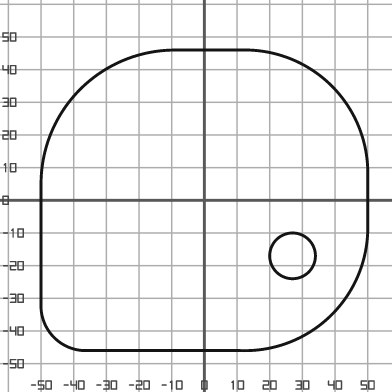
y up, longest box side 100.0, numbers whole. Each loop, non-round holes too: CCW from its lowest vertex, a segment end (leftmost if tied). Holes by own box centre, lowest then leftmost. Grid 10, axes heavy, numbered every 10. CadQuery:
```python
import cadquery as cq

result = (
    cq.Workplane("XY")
    .moveTo(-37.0, -46.0)
    .lineTo(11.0, -46.0)
    .threePointArc((39.0, -35.0), (50.0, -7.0))
    .lineTo(50.0, 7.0)
    .threePointArc((39.0, 35.0), (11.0, 46.0))
    .lineTo(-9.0, 46.0)
    .threePointArc((-38.0, 34.0), (-50.0, 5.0))
    .lineTo(-50.0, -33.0)
    .threePointArc((-46.0, -42.0), (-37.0, -46.0))
    .close()
    .moveTo(27.0, -17.0)
    .circle(7.0)
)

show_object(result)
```